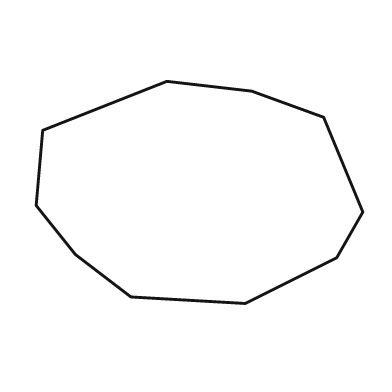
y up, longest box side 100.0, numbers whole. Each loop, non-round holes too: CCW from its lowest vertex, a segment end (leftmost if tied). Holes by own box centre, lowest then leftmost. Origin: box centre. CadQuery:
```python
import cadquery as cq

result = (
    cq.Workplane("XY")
    .moveTo(14.0, -34.0)
    .lineTo(42.0, -20.0)
    .lineTo(50.0, -6.0)
    .lineTo(38.0, 23.0)
    .lineTo(16.0, 31.0)
    .lineTo(-10.0, 34.0)
    .lineTo(-48.0, 19.0)
    .lineTo(-50.0, -4.0)
    .lineTo(-38.0, -19.0)
    .lineTo(-21.0, -32.0)
    .close()
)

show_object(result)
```